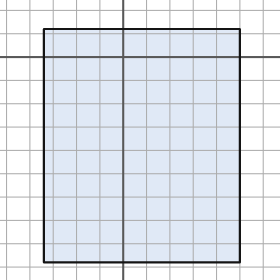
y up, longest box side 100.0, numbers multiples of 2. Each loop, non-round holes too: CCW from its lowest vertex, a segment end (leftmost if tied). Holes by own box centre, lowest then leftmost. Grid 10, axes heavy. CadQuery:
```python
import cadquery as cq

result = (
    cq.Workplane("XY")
    .moveTo(-34.0, -88.0)
    .lineTo(50.0, -88.0)
    .lineTo(50.0, 12.0)
    .lineTo(-34.0, 12.0)
    .close()
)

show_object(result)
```